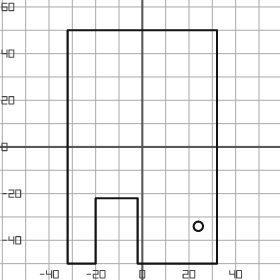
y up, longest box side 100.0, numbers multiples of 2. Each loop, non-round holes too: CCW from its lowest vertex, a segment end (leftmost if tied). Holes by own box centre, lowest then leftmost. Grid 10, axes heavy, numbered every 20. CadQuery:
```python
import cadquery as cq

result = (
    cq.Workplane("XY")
    .moveTo(-32.0, -50.0)
    .lineTo(-20.0, -50.0)
    .lineTo(-20.0, -22.0)
    .lineTo(-2.0, -22.0)
    .lineTo(-2.0, -50.0)
    .lineTo(32.0, -50.0)
    .lineTo(32.0, 50.0)
    .lineTo(-32.0, 50.0)
    .close()
    .moveTo(24.0, -34.0)
    .circle(2.0)
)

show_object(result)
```